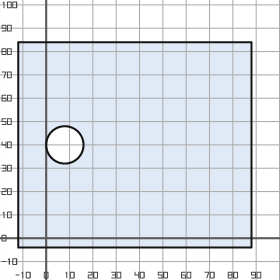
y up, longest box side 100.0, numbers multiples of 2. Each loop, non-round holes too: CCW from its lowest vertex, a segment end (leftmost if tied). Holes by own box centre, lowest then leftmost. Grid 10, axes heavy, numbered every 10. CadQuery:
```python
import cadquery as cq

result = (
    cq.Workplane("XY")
    .moveTo(-12.0, -4.0)
    .lineTo(88.0, -4.0)
    .lineTo(88.0, 84.0)
    .lineTo(-12.0, 84.0)
    .close()
    .moveTo(8.0, 40.0)
    .circle(8.0)
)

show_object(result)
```